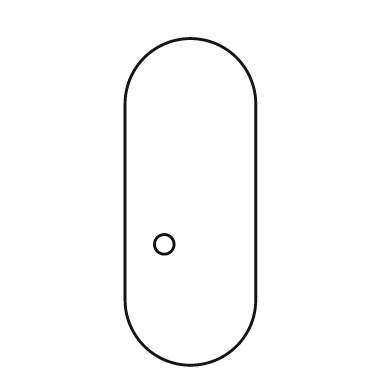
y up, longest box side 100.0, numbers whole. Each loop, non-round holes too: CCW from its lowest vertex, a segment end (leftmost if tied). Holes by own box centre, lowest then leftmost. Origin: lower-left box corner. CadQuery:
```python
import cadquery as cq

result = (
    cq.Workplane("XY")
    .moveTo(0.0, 20.0)
    .threePointArc((20.0, 0.0), (40.0, 20.0))
    .lineTo(40.0, 80.0)
    .threePointArc((20.0, 100.0), (0.0, 80.0))
    .close()
    .moveTo(12.0, 37.0)
    .circle(3.0)
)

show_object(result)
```